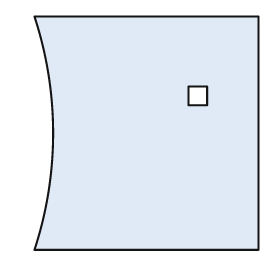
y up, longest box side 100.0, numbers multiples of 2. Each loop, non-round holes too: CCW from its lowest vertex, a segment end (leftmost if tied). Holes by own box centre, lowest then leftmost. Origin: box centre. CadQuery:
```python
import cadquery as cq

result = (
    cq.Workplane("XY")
    .moveTo(-48.0, -50.0)
    .lineTo(48.0, -50.0)
    .lineTo(48.0, 50.0)
    .lineTo(-48.0, 50.0)
    .threePointArc((-40.0, 0.0), (-48.0, -50.0))
    .close()
    .moveTo(18.0, 12.0)
    .lineTo(26.0, 12.0)
    .lineTo(26.0, 20.0)
    .lineTo(18.0, 20.0)
    .close()
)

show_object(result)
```